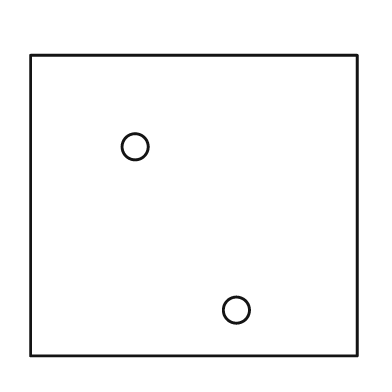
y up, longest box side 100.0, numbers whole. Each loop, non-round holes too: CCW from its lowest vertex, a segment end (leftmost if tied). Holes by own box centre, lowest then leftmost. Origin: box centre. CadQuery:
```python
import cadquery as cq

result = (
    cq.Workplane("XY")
    .moveTo(-50.0, -46.0)
    .lineTo(50.0, -46.0)
    .lineTo(50.0, 46.0)
    .lineTo(-50.0, 46.0)
    .close()
    .moveTo(13.0, -32.0)
    .circle(4.0)
    .moveTo(-18.0, 18.0)
    .circle(4.0)
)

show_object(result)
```